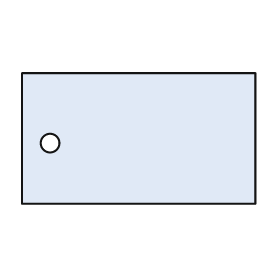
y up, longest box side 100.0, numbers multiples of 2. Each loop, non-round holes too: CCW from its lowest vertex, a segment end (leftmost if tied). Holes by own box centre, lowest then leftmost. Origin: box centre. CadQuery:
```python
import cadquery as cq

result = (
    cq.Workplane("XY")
    .moveTo(-50.0, -28.0)
    .lineTo(50.0, -28.0)
    .lineTo(50.0, 28.0)
    .lineTo(-50.0, 28.0)
    .close()
    .moveTo(-38.0, -2.0)
    .circle(4.0)
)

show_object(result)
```